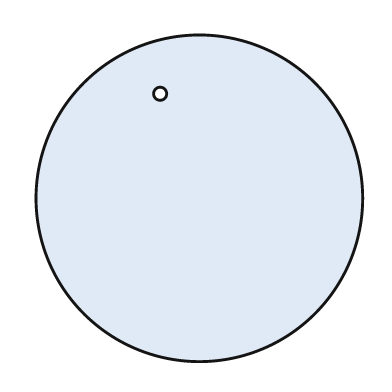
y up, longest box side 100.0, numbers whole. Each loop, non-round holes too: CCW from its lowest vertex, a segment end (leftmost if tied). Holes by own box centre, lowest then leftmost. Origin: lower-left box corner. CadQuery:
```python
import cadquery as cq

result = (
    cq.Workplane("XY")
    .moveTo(50.0, 50.0)
    .circle(50.0)
    .moveTo(38.0, 82.0)
    .circle(2.0)
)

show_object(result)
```